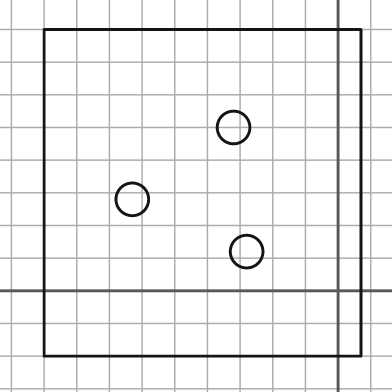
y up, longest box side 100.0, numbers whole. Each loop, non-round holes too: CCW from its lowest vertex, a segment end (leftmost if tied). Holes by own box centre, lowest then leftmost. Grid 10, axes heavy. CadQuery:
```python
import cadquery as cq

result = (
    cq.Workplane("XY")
    .moveTo(-90.0, -20.0)
    .lineTo(7.0, -20.0)
    .lineTo(7.0, 80.0)
    .lineTo(-90.0, 80.0)
    .close()
    .moveTo(-28.0, 12.0)
    .circle(5.0)
    .moveTo(-63.0, 28.0)
    .circle(5.0)
    .moveTo(-32.0, 50.0)
    .circle(5.0)
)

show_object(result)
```